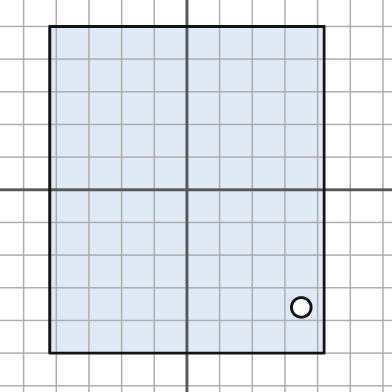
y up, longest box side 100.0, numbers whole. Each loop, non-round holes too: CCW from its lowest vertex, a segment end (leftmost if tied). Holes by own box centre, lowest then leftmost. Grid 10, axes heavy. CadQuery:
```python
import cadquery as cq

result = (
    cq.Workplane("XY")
    .moveTo(-42.0, -50.0)
    .lineTo(42.0, -50.0)
    .lineTo(42.0, 50.0)
    .lineTo(-42.0, 50.0)
    .close()
    .moveTo(35.0, -36.0)
    .circle(3.0)
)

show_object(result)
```